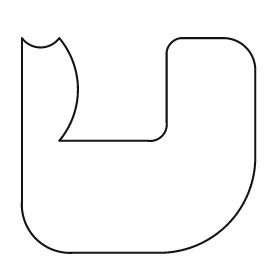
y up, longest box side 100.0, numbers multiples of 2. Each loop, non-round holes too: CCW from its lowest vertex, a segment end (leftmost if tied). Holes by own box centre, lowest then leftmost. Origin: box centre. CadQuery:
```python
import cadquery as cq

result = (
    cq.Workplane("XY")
    .moveTo(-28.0, -46.0)
    .lineTo(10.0, -46.0)
    .threePointArc((38.0, -34.0), (50.0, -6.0))
    .lineTo(50.0, 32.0)
    .threePointArc((46.0, 42.0), (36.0, 46.0))
    .lineTo(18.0, 46.0)
    .threePointArc((14.0, 44.0), (12.0, 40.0))
    .lineTo(12.0, 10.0)
    .threePointArc((10.0, 4.0), (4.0, 2.0))
    .lineTo(-34.0, 2.0)
    .threePointArc((-26.0, 24.0), (-34.0, 46.0))
    .threePointArc((-42.0, 42.0), (-50.0, 46.0))
    .lineTo(-50.0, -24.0)
    .threePointArc((-44.0, -40.0), (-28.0, -46.0))
    .close()
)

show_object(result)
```